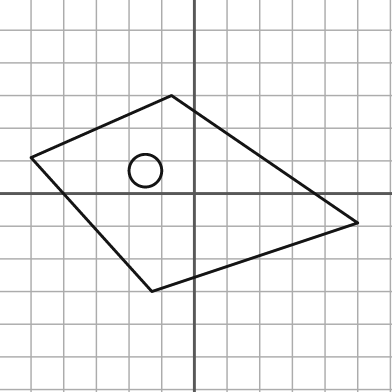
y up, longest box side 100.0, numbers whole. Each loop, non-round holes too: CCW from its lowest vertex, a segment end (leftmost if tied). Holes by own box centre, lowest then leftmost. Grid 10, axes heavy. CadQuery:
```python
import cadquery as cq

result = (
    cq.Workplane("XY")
    .moveTo(-13.0, -30.0)
    .lineTo(50.0, -9.0)
    .lineTo(-7.0, 30.0)
    .lineTo(-50.0, 11.0)
    .close()
    .moveTo(-15.0, 7.0)
    .circle(5.0)
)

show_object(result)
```